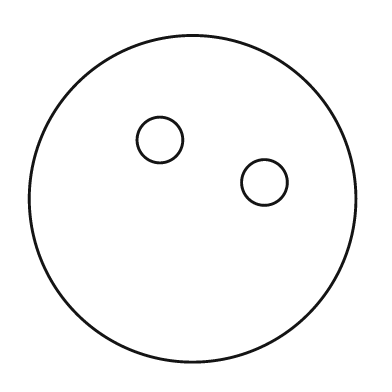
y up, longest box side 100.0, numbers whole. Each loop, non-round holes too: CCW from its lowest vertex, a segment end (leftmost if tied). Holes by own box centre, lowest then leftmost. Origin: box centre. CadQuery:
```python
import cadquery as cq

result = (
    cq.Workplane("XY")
    .moveTo(0.0, 0.0)
    .circle(50.0)
    .moveTo(22.0, 5.0)
    .circle(7.0)
    .moveTo(-10.0, 18.0)
    .circle(7.0)
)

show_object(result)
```